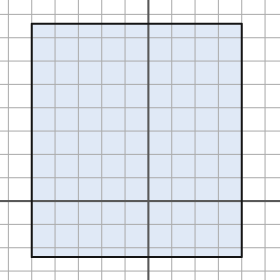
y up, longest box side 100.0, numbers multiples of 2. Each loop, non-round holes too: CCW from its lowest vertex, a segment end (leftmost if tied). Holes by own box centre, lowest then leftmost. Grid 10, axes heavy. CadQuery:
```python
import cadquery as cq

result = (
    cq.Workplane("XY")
    .moveTo(-50.0, -24.0)
    .lineTo(40.0, -24.0)
    .lineTo(40.0, 76.0)
    .lineTo(-50.0, 76.0)
    .close()
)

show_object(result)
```